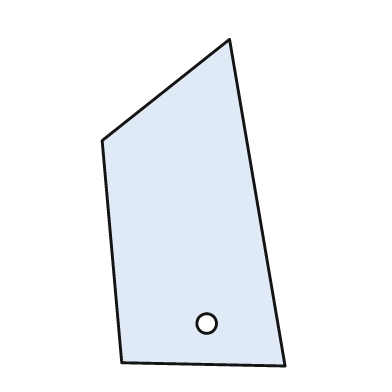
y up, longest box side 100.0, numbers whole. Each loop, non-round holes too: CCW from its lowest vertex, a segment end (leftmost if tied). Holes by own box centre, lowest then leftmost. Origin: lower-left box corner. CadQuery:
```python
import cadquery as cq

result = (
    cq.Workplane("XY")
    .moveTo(56.0, 0.0)
    .lineTo(39.0, 100.0)
    .lineTo(0.0, 69.0)
    .lineTo(6.0, 1.0)
    .close()
    .moveTo(32.0, 13.0)
    .circle(3.0)
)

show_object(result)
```